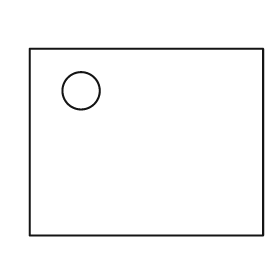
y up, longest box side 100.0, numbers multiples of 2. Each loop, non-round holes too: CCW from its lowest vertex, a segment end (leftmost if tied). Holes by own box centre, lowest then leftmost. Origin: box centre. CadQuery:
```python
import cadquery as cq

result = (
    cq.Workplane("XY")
    .moveTo(-50.0, -40.0)
    .lineTo(50.0, -40.0)
    .lineTo(50.0, 40.0)
    .lineTo(-50.0, 40.0)
    .close()
    .moveTo(-28.0, 22.0)
    .circle(8.0)
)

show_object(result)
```